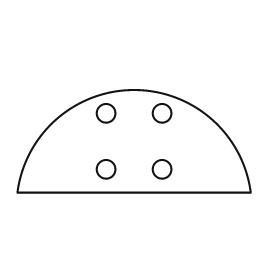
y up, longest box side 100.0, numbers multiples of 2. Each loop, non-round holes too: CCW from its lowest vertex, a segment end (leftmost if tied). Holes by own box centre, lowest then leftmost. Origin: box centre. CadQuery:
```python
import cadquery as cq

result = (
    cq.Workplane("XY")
    .moveTo(-50.0, -22.0)
    .lineTo(50.0, -22.0)
    .threePointArc((0.0, 22.0), (-50.0, -22.0))
    .close()
    .moveTo(-12.0, -12.0)
    .circle(4.0)
    .moveTo(12.0, -12.0)
    .circle(4.0)
    .moveTo(-12.0, 12.0)
    .circle(4.0)
    .moveTo(12.0, 12.0)
    .circle(4.0)
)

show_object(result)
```